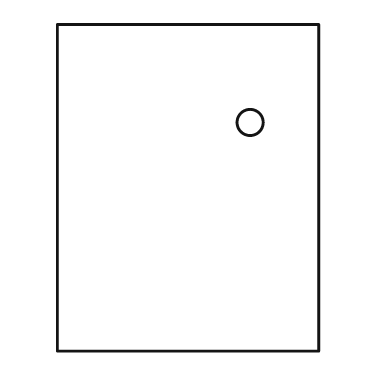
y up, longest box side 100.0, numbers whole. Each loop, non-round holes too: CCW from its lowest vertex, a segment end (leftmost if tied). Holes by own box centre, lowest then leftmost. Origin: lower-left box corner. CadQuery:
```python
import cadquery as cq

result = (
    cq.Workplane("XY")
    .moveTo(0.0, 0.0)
    .lineTo(80.0, 0.0)
    .lineTo(80.0, 100.0)
    .lineTo(0.0, 100.0)
    .close()
    .moveTo(59.0, 70.0)
    .circle(4.0)
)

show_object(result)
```